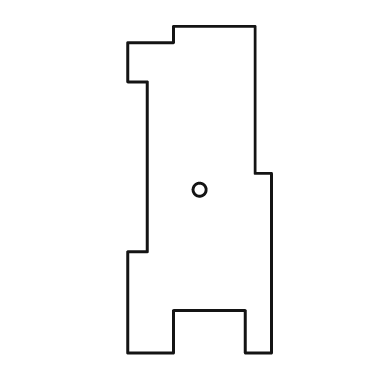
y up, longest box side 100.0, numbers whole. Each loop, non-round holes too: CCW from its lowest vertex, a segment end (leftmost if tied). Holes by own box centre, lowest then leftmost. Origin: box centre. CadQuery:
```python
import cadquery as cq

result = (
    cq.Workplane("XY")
    .moveTo(-22.0, -50.0)
    .lineTo(-8.0, -50.0)
    .lineTo(-8.0, -37.0)
    .lineTo(14.0, -37.0)
    .lineTo(14.0, -50.0)
    .lineTo(22.0, -50.0)
    .lineTo(22.0, 5.0)
    .lineTo(17.0, 5.0)
    .lineTo(17.0, 50.0)
    .lineTo(-8.0, 50.0)
    .lineTo(-8.0, 45.0)
    .lineTo(-22.0, 45.0)
    .lineTo(-22.0, 33.0)
    .lineTo(-16.0, 33.0)
    .lineTo(-16.0, -19.0)
    .lineTo(-22.0, -19.0)
    .close()
    .moveTo(0.0, 0.0)
    .circle(2.0)
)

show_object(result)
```